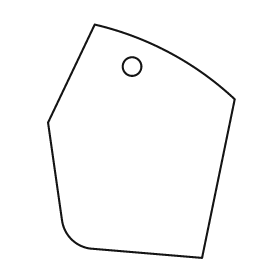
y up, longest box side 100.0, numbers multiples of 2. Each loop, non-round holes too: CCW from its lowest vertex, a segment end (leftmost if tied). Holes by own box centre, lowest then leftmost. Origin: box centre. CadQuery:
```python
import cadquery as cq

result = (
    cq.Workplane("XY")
    .moveTo(26.0, -50.0)
    .lineTo(40.0, 18.0)
    .threePointArc((12.0, 38.0), (-20.0, 50.0))
    .lineTo(-40.0, 8.0)
    .lineTo(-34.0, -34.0)
    .threePointArc((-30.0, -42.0), (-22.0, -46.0))
    .close()
    .moveTo(-4.0, 32.0)
    .circle(4.0)
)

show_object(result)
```